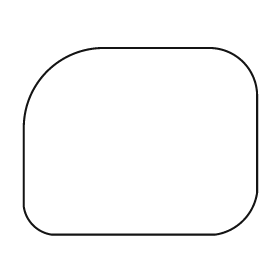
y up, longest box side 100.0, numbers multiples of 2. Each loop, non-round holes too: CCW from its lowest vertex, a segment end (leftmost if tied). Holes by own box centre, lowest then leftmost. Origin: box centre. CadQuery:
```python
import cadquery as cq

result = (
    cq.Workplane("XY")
    .moveTo(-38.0, -40.0)
    .lineTo(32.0, -40.0)
    .threePointArc((44.0, -34.0), (50.0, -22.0))
    .lineTo(50.0, 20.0)
    .threePointArc((44.0, 34.0), (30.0, 40.0))
    .lineTo(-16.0, 40.0)
    .threePointArc((-40.0, 30.0), (-50.0, 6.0))
    .lineTo(-50.0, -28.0)
    .threePointArc((-46.0, -36.0), (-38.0, -40.0))
    .close()
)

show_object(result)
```